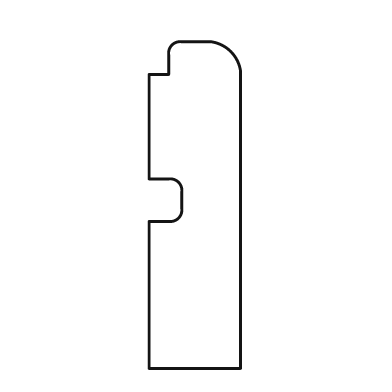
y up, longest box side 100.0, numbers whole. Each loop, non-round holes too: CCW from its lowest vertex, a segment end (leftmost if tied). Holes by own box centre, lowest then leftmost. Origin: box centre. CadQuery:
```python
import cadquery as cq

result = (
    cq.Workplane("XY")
    .moveTo(-14.0, -50.0)
    .lineTo(14.0, -50.0)
    .lineTo(14.0, 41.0)
    .threePointArc((11.0, 47.0), (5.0, 50.0))
    .lineTo(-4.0, 50.0)
    .threePointArc((-7.0, 49.0), (-8.0, 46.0))
    .lineTo(-8.0, 40.0)
    .lineTo(-14.0, 40.0)
    .lineTo(-14.0, 8.0)
    .lineTo(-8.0, 8.0)
    .threePointArc((-5.0, 7.0), (-4.0, 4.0))
    .lineTo(-4.0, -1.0)
    .threePointArc((-5.0, -4.0), (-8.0, -5.0))
    .lineTo(-14.0, -5.0)
    .close()
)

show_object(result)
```